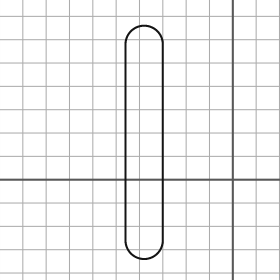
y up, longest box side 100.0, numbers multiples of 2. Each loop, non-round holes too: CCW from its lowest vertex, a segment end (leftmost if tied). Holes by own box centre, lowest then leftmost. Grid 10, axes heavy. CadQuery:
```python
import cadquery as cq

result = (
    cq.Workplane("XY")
    .moveTo(-46.0, -26.0)
    .threePointArc((-38.0, -34.0), (-30.0, -26.0))
    .lineTo(-30.0, 58.0)
    .threePointArc((-38.0, 66.0), (-46.0, 58.0))
    .close()
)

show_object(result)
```